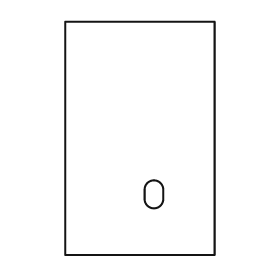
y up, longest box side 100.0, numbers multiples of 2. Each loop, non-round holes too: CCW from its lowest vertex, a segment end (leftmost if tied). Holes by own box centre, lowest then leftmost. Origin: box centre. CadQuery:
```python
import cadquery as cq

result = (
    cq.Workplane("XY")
    .moveTo(-32.0, -50.0)
    .lineTo(32.0, -50.0)
    .lineTo(32.0, 50.0)
    .lineTo(-32.0, 50.0)
    .close()
    .moveTo(2.0, -26.0)
    .threePointArc((6.0, -30.0), (10.0, -26.0))
    .lineTo(10.0, -22.0)
    .threePointArc((6.0, -18.0), (2.0, -22.0))
    .close()
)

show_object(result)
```